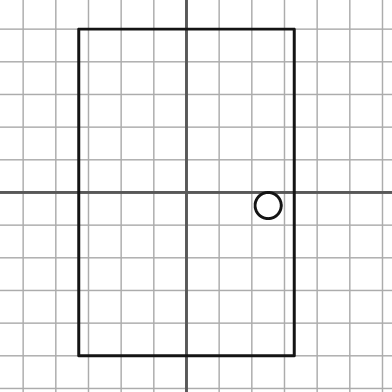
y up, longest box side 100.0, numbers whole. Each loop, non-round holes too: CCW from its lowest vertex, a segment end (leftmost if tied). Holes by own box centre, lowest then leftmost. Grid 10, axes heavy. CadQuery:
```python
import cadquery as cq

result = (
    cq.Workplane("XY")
    .moveTo(-33.0, -50.0)
    .lineTo(33.0, -50.0)
    .lineTo(33.0, 50.0)
    .lineTo(-33.0, 50.0)
    .close()
    .moveTo(25.0, -4.0)
    .circle(4.0)
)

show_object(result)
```